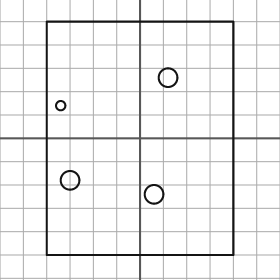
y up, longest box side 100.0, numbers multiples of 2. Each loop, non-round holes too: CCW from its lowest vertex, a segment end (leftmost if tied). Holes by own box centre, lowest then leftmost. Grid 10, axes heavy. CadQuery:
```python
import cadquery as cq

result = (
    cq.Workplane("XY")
    .moveTo(-40.0, -50.0)
    .lineTo(40.0, -50.0)
    .lineTo(40.0, 50.0)
    .lineTo(-40.0, 50.0)
    .close()
    .moveTo(6.0, -24.0)
    .circle(4.0)
    .moveTo(-30.0, -18.0)
    .circle(4.0)
    .moveTo(-34.0, 14.0)
    .circle(2.0)
    .moveTo(12.0, 26.0)
    .circle(4.0)
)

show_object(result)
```